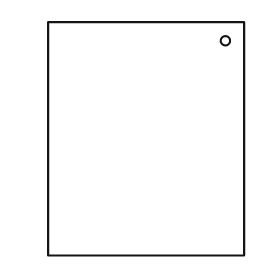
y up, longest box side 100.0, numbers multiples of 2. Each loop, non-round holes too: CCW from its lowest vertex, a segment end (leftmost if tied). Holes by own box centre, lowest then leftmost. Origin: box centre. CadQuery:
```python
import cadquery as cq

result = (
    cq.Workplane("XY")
    .moveTo(-42.0, -50.0)
    .lineTo(42.0, -50.0)
    .lineTo(42.0, 50.0)
    .lineTo(-42.0, 50.0)
    .close()
    .moveTo(34.0, 42.0)
    .circle(2.0)
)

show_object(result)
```